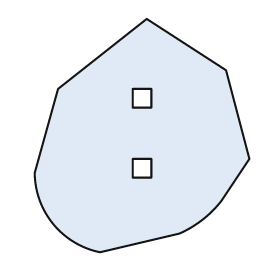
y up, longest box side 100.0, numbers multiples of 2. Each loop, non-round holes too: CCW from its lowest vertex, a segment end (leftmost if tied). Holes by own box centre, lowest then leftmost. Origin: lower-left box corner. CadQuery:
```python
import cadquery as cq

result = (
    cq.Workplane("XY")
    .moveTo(28.0, 0.0)
    .lineTo(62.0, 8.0)
    .threePointArc((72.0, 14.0), (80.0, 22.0))
    .lineTo(92.0, 40.0)
    .lineTo(82.0, 78.0)
    .lineTo(48.0, 100.0)
    .lineTo(10.0, 70.0)
    .lineTo(0.0, 34.0)
    .threePointArc((8.0, 12.0), (28.0, 0.0))
    .close()
    .moveTo(42.0, 32.0)
    .lineTo(50.0, 32.0)
    .lineTo(50.0, 40.0)
    .lineTo(42.0, 40.0)
    .close()
    .moveTo(42.0, 62.0)
    .lineTo(50.0, 62.0)
    .lineTo(50.0, 70.0)
    .lineTo(42.0, 70.0)
    .close()
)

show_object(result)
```